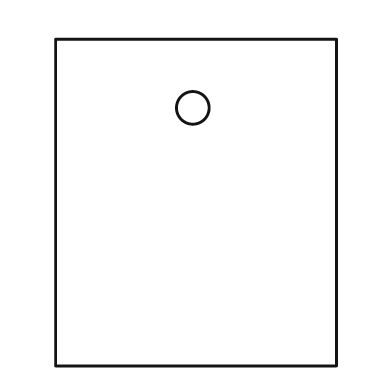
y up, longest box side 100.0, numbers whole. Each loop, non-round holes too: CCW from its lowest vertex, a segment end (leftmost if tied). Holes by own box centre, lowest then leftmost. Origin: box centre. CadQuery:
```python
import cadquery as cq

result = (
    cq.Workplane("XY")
    .moveTo(-43.0, -50.0)
    .lineTo(43.0, -50.0)
    .lineTo(43.0, 50.0)
    .lineTo(-43.0, 50.0)
    .close()
    .moveTo(-1.0, 29.0)
    .circle(5.0)
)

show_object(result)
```